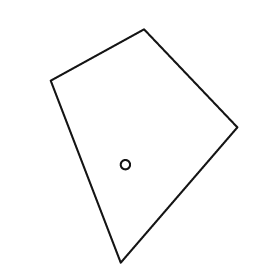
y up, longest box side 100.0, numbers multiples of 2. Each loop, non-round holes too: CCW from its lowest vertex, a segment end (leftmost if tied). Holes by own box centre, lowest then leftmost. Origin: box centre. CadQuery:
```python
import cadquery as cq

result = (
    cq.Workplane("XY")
    .moveTo(-10.0, -50.0)
    .lineTo(40.0, 8.0)
    .lineTo(0.0, 50.0)
    .lineTo(-40.0, 28.0)
    .close()
    .moveTo(-8.0, -8.0)
    .circle(2.0)
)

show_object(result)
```